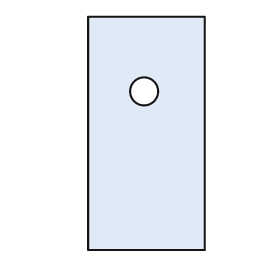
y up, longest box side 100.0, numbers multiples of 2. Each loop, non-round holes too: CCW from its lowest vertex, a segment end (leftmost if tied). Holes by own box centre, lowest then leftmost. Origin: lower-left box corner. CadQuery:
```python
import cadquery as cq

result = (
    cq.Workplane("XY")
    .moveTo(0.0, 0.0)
    .lineTo(50.0, 0.0)
    .lineTo(50.0, 100.0)
    .lineTo(0.0, 100.0)
    .close()
    .moveTo(24.0, 68.0)
    .circle(6.0)
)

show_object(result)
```